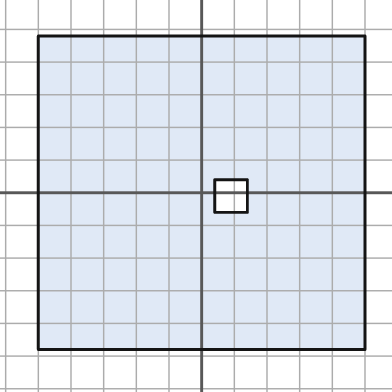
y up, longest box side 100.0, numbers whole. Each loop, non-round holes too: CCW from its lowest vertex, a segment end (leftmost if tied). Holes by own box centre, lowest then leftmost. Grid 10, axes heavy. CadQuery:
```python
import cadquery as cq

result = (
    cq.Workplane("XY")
    .moveTo(-50.0, -48.0)
    .lineTo(50.0, -48.0)
    .lineTo(50.0, 48.0)
    .lineTo(-50.0, 48.0)
    .close()
    .moveTo(4.0, -6.0)
    .lineTo(14.0, -6.0)
    .lineTo(14.0, 4.0)
    .lineTo(4.0, 4.0)
    .close()
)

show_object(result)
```